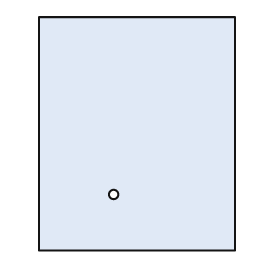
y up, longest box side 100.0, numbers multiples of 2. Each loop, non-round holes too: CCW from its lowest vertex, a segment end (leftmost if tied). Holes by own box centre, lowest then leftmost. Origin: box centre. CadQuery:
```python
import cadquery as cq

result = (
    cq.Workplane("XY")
    .moveTo(-42.0, -50.0)
    .lineTo(42.0, -50.0)
    .lineTo(42.0, 50.0)
    .lineTo(-42.0, 50.0)
    .close()
    .moveTo(-10.0, -26.0)
    .circle(2.0)
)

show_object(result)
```